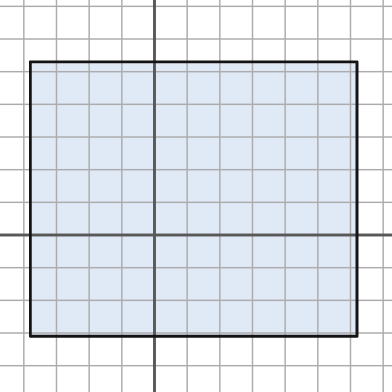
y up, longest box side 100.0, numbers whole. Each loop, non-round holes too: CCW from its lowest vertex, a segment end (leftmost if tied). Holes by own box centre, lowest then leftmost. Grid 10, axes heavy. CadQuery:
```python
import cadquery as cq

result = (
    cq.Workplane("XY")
    .moveTo(-38.0, -31.0)
    .lineTo(62.0, -31.0)
    .lineTo(62.0, 53.0)
    .lineTo(-38.0, 53.0)
    .close()
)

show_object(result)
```